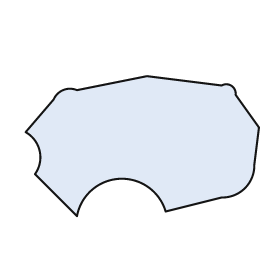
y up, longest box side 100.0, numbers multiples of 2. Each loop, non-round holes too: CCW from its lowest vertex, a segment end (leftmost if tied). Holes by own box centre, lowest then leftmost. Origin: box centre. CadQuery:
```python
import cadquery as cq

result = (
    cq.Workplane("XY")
    .moveTo(-28.0, -30.0)
    .threePointArc((-10.0, -14.0), (10.0, -28.0))
    .lineTo(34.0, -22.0)
    .threePointArc((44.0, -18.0), (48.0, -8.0))
    .lineTo(50.0, 8.0)
    .lineTo(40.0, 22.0)
    .threePointArc((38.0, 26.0), (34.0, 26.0))
    .lineTo(2.0, 30.0)
    .lineTo(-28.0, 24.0)
    .threePointArc((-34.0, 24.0), (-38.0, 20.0))
    .lineTo(-50.0, 6.0)
    .threePointArc((-44.0, -2.0), (-46.0, -12.0))
    .close()
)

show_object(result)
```